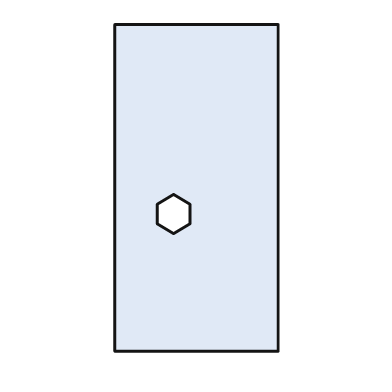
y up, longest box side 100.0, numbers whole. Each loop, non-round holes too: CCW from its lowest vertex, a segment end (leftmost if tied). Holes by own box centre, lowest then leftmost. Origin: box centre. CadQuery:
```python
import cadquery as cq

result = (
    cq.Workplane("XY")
    .moveTo(-25.0, -50.0)
    .lineTo(25.0, -50.0)
    .lineTo(25.0, 50.0)
    .lineTo(-25.0, 50.0)
    .close()
    .moveTo(-7.0, -14.0)
    .lineTo(-2.0, -11.0)
    .lineTo(-2.0, -5.0)
    .lineTo(-7.0, -2.0)
    .lineTo(-12.0, -5.0)
    .lineTo(-12.0, -11.0)
    .close()
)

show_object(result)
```